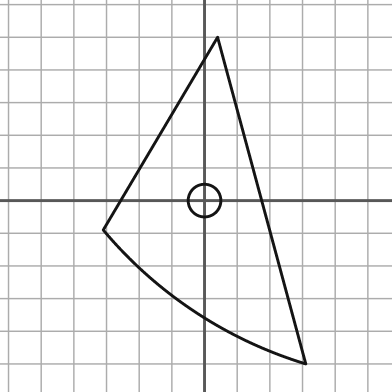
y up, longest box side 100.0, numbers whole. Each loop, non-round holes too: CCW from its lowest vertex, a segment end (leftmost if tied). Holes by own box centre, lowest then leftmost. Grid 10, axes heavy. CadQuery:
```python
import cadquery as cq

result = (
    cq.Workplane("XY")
    .moveTo(31.0, -50.0)
    .lineTo(4.0, 50.0)
    .lineTo(-31.0, -9.0)
    .threePointArc((-3.0, -34.0), (31.0, -50.0))
    .close()
    .moveTo(0.0, 0.0)
    .circle(5.0)
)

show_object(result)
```